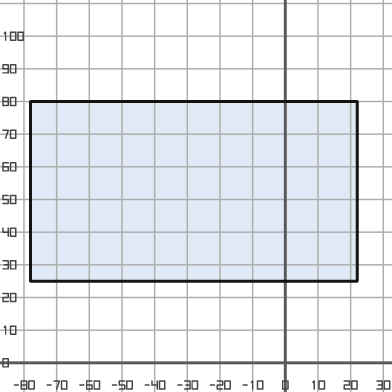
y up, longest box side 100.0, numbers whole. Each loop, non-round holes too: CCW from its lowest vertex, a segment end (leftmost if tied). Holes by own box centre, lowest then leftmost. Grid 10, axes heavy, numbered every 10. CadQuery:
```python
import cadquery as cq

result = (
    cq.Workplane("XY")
    .moveTo(-78.0, 25.0)
    .lineTo(22.0, 25.0)
    .lineTo(22.0, 80.0)
    .lineTo(-78.0, 80.0)
    .close()
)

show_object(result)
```